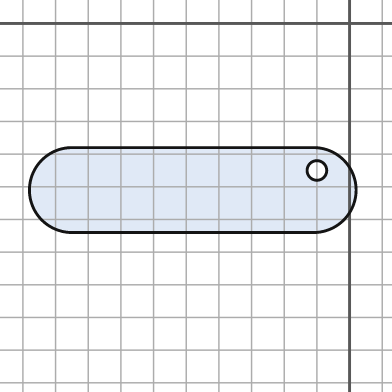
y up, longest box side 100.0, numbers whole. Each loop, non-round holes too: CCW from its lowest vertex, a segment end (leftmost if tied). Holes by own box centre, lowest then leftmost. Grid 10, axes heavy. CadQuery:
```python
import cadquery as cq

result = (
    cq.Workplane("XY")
    .moveTo(-85.0, -64.0)
    .lineTo(-11.0, -64.0)
    .threePointArc((2.0, -51.0), (-11.0, -38.0))
    .lineTo(-85.0, -38.0)
    .threePointArc((-98.0, -51.0), (-85.0, -64.0))
    .close()
    .moveTo(-10.0, -45.0)
    .circle(3.0)
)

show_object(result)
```